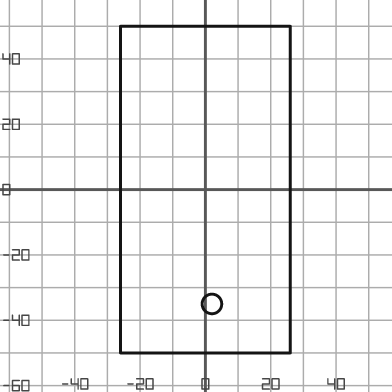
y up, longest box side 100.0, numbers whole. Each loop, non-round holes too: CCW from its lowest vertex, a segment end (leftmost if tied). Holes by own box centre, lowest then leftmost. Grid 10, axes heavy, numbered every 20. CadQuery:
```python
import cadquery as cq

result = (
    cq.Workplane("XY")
    .moveTo(-26.0, -50.0)
    .lineTo(26.0, -50.0)
    .lineTo(26.0, 50.0)
    .lineTo(-26.0, 50.0)
    .close()
    .moveTo(2.0, -35.0)
    .circle(3.0)
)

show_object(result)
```